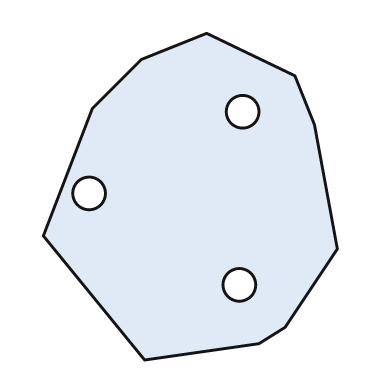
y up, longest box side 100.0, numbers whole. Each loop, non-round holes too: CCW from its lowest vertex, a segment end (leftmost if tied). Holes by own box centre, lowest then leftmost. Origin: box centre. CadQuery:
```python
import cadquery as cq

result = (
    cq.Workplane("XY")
    .moveTo(-14.0, -50.0)
    .lineTo(21.0, -45.0)
    .lineTo(29.0, -40.0)
    .lineTo(45.0, -16.0)
    .lineTo(38.0, 22.0)
    .lineTo(32.0, 37.0)
    .lineTo(5.0, 50.0)
    .lineTo(-15.0, 42.0)
    .lineTo(-30.0, 27.0)
    .lineTo(-45.0, -12.0)
    .close()
    .moveTo(15.0, -27.0)
    .circle(5.0)
    .moveTo(-31.0, 1.0)
    .circle(5.0)
    .moveTo(16.0, 26.0)
    .circle(5.0)
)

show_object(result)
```